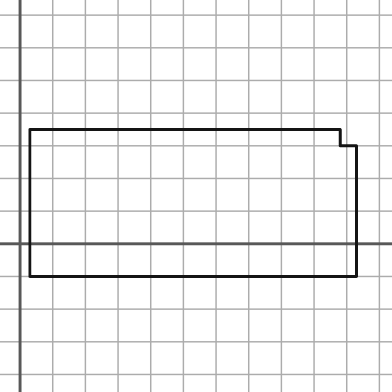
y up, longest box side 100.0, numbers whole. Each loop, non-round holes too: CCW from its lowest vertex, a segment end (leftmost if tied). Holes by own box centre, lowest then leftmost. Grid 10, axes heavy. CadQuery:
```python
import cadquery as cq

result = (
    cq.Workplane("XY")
    .moveTo(3.0, -10.0)
    .lineTo(103.0, -10.0)
    .lineTo(103.0, 30.0)
    .lineTo(98.0, 30.0)
    .lineTo(98.0, 35.0)
    .lineTo(3.0, 35.0)
    .close()
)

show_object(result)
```